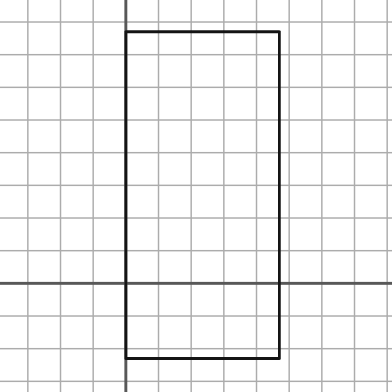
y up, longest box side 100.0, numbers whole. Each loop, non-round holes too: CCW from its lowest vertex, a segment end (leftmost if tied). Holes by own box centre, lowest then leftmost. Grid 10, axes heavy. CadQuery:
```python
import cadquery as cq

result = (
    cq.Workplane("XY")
    .moveTo(0.0, -23.0)
    .lineTo(47.0, -23.0)
    .lineTo(47.0, 77.0)
    .lineTo(0.0, 77.0)
    .close()
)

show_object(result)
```